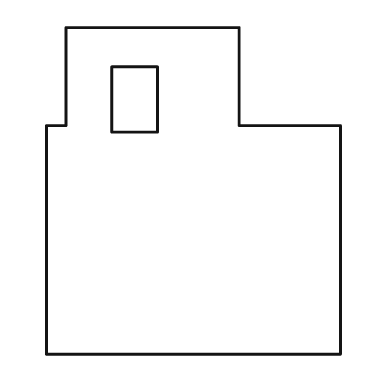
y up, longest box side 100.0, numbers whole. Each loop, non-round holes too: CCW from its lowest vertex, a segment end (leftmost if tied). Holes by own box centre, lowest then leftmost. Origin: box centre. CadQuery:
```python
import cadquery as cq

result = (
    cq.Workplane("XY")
    .moveTo(-45.0, -50.0)
    .lineTo(45.0, -50.0)
    .lineTo(45.0, 20.0)
    .lineTo(14.0, 20.0)
    .lineTo(14.0, 50.0)
    .lineTo(-39.0, 50.0)
    .lineTo(-39.0, 20.0)
    .lineTo(-45.0, 20.0)
    .close()
    .moveTo(-25.0, 18.0)
    .lineTo(-11.0, 18.0)
    .lineTo(-11.0, 38.0)
    .lineTo(-25.0, 38.0)
    .close()
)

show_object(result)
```